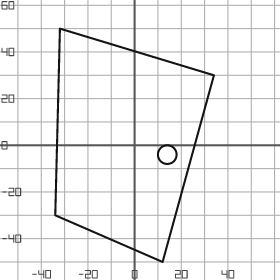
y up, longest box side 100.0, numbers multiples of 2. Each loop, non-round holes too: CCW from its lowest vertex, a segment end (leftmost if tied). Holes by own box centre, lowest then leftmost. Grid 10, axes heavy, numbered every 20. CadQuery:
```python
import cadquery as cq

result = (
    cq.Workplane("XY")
    .moveTo(12.0, -50.0)
    .lineTo(34.0, 30.0)
    .lineTo(-32.0, 50.0)
    .lineTo(-34.0, -30.0)
    .close()
    .moveTo(14.0, -4.0)
    .circle(4.0)
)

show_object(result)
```